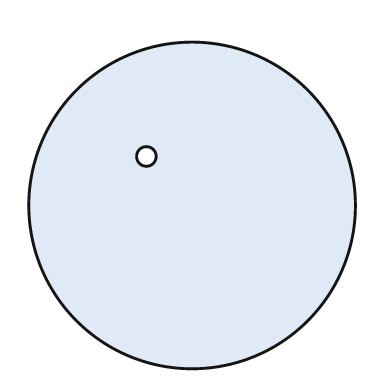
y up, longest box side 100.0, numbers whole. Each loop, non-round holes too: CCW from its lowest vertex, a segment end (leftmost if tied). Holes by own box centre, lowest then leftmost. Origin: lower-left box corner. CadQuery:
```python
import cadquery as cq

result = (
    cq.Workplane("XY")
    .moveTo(50.0, 50.0)
    .circle(50.0)
    .moveTo(36.0, 65.0)
    .circle(3.0)
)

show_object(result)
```